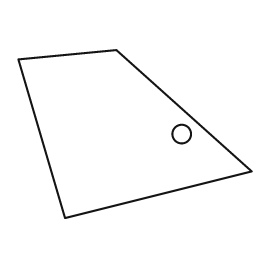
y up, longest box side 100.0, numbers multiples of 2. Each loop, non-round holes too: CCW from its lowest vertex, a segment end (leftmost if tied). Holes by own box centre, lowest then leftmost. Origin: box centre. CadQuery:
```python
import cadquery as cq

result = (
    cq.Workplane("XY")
    .moveTo(-30.0, -36.0)
    .lineTo(50.0, -16.0)
    .lineTo(-8.0, 36.0)
    .lineTo(-50.0, 32.0)
    .close()
    .moveTo(20.0, 0.0)
    .circle(4.0)
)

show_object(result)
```